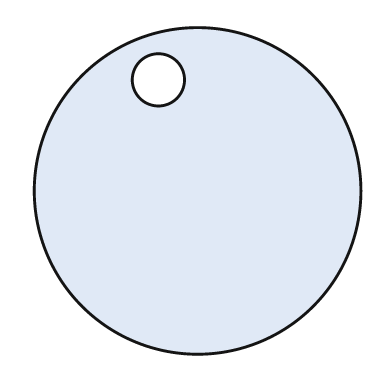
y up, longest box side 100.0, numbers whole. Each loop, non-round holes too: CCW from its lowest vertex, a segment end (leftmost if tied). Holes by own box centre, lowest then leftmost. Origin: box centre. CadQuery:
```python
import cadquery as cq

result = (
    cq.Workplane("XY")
    .moveTo(0.0, 0.0)
    .circle(50.0)
    .moveTo(-12.0, 34.0)
    .circle(8.0)
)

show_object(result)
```